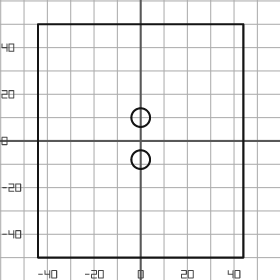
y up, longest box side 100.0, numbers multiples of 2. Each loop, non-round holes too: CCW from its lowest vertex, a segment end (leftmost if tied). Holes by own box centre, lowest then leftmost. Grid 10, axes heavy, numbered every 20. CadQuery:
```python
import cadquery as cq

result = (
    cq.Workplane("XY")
    .moveTo(-44.0, -50.0)
    .lineTo(44.0, -50.0)
    .lineTo(44.0, 50.0)
    .lineTo(-44.0, 50.0)
    .close()
    .moveTo(0.0, -8.0)
    .circle(4.0)
    .moveTo(0.0, 10.0)
    .circle(4.0)
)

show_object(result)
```